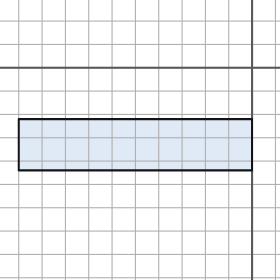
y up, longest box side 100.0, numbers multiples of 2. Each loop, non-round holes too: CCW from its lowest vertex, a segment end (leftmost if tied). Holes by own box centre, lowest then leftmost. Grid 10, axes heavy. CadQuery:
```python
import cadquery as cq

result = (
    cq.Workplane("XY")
    .moveTo(-100.0, -44.0)
    .lineTo(0.0, -44.0)
    .lineTo(0.0, -22.0)
    .lineTo(-100.0, -22.0)
    .close()
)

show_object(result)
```